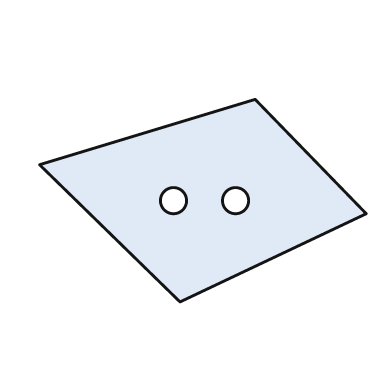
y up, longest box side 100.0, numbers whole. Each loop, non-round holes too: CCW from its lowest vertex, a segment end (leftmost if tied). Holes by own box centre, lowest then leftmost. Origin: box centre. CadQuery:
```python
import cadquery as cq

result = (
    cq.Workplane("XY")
    .moveTo(-7.0, -31.0)
    .lineTo(50.0, -4.0)
    .lineTo(16.0, 31.0)
    .lineTo(-50.0, 11.0)
    .close()
    .moveTo(-9.0, 0.0)
    .circle(4.0)
    .moveTo(10.0, 0.0)
    .circle(4.0)
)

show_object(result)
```